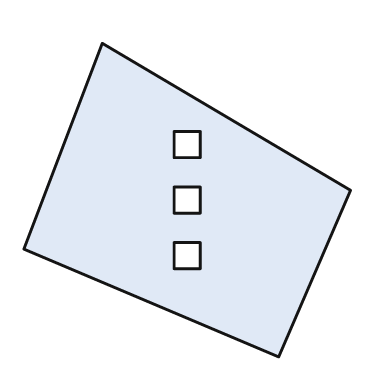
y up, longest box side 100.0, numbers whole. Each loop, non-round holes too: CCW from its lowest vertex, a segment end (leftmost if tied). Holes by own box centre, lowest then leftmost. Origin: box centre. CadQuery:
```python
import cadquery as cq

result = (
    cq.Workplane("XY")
    .moveTo(28.0, -48.0)
    .lineTo(50.0, 3.0)
    .lineTo(-26.0, 48.0)
    .lineTo(-50.0, -15.0)
    .close()
    .moveTo(-4.0, -21.0)
    .lineTo(4.0, -21.0)
    .lineTo(4.0, -13.0)
    .lineTo(-4.0, -13.0)
    .close()
    .moveTo(-4.0, -4.0)
    .lineTo(4.0, -4.0)
    .lineTo(4.0, 4.0)
    .lineTo(-4.0, 4.0)
    .close()
    .moveTo(-4.0, 13.0)
    .lineTo(4.0, 13.0)
    .lineTo(4.0, 21.0)
    .lineTo(-4.0, 21.0)
    .close()
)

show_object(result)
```